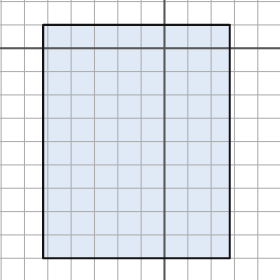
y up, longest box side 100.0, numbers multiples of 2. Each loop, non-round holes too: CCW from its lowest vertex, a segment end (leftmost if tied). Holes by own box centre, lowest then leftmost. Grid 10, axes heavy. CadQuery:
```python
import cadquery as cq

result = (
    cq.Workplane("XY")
    .moveTo(-52.0, -90.0)
    .lineTo(28.0, -90.0)
    .lineTo(28.0, 10.0)
    .lineTo(-52.0, 10.0)
    .close()
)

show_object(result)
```